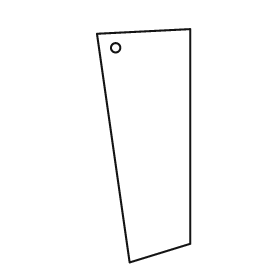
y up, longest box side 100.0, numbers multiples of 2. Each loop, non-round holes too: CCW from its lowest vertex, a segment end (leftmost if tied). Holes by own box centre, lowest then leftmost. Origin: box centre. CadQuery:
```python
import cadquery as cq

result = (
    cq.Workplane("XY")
    .moveTo(-6.0, -50.0)
    .lineTo(20.0, -42.0)
    .lineTo(20.0, 50.0)
    .lineTo(-20.0, 48.0)
    .close()
    .moveTo(-12.0, 42.0)
    .circle(2.0)
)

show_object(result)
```